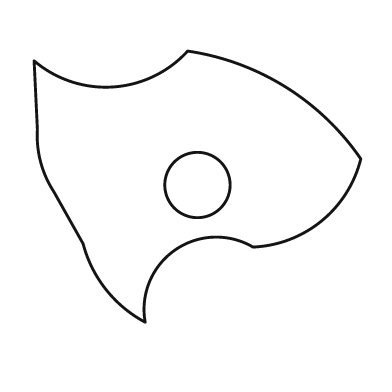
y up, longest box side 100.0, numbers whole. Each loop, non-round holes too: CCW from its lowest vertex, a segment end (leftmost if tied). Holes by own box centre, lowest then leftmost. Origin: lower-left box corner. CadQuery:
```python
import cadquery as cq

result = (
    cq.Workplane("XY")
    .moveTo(34.0, 0.0)
    .threePointArc((43.0, 22.0), (67.0, 23.0))
    .threePointArc((88.0, 31.0), (100.0, 50.0))
    .threePointArc((77.0, 72.0), (47.0, 83.0))
    .threePointArc((24.0, 72.0), (0.0, 80.0))
    .lineTo(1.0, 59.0)
    .threePointArc((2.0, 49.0), (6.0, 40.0))
    .lineTo(15.0, 24.0)
    .threePointArc((22.0, 10.0), (34.0, 0.0))
    .close()
    .moveTo(50.0, 42.0)
    .circle(10.0)
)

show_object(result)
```